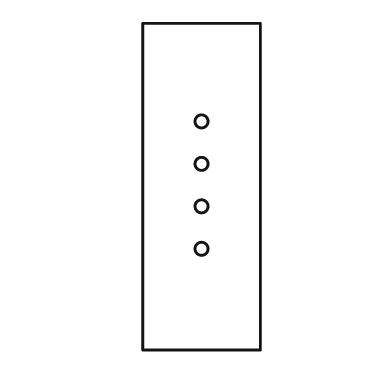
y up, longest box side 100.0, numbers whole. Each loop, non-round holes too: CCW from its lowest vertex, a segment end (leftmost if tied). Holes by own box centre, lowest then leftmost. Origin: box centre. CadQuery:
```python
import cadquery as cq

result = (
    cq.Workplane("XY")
    .moveTo(-18.0, -50.0)
    .lineTo(18.0, -50.0)
    .lineTo(18.0, 50.0)
    .lineTo(-18.0, 50.0)
    .close()
    .moveTo(0.0, -19.0)
    .circle(2.0)
    .moveTo(0.0, -6.0)
    .circle(2.0)
    .moveTo(0.0, 7.0)
    .circle(2.0)
    .moveTo(0.0, 20.0)
    .circle(2.0)
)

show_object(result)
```